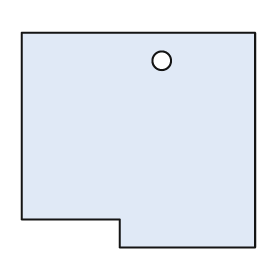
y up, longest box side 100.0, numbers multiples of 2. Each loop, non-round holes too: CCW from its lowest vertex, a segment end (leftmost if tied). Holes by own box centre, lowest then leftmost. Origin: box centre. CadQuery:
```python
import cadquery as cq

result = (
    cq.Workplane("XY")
    .moveTo(-8.0, -46.0)
    .lineTo(50.0, -46.0)
    .lineTo(50.0, 46.0)
    .lineTo(-50.0, 46.0)
    .lineTo(-50.0, -34.0)
    .lineTo(-8.0, -34.0)
    .close()
    .moveTo(10.0, 34.0)
    .circle(4.0)
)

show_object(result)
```